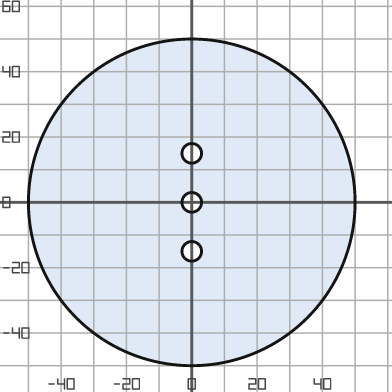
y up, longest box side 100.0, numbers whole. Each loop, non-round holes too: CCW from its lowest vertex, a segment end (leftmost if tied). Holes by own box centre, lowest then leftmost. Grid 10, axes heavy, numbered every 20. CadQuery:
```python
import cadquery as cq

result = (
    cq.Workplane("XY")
    .moveTo(0.0, 0.0)
    .circle(50.0)
    .moveTo(0.0, -15.0)
    .circle(3.0)
    .moveTo(0.0, 0.0)
    .circle(3.0)
    .moveTo(0.0, 15.0)
    .circle(3.0)
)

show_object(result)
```